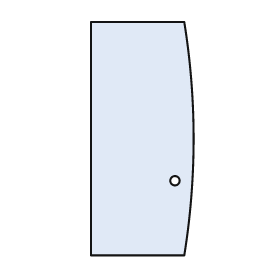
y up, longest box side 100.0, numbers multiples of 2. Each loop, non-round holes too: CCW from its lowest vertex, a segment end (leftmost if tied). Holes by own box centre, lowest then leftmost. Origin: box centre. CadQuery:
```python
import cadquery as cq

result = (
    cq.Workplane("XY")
    .moveTo(-22.0, -50.0)
    .lineTo(18.0, -50.0)
    .threePointArc((22.0, 0.0), (18.0, 50.0))
    .lineTo(-22.0, 50.0)
    .close()
    .moveTo(14.0, -18.0)
    .circle(2.0)
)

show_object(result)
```